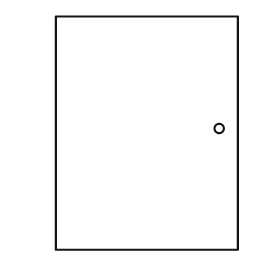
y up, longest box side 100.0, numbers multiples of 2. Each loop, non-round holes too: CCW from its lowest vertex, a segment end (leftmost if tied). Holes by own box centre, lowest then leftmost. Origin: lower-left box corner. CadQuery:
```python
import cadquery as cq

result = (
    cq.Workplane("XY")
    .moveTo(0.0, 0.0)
    .lineTo(78.0, 0.0)
    .lineTo(78.0, 100.0)
    .lineTo(0.0, 100.0)
    .close()
    .moveTo(70.0, 52.0)
    .circle(2.0)
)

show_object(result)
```